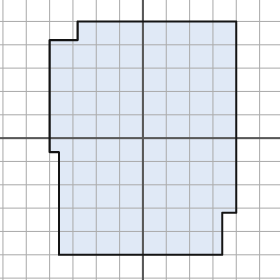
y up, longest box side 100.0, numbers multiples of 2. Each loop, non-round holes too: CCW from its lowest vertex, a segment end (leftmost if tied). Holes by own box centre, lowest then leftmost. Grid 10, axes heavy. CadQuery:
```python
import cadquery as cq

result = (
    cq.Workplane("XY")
    .moveTo(-36.0, -50.0)
    .lineTo(34.0, -50.0)
    .lineTo(34.0, -32.0)
    .lineTo(40.0, -32.0)
    .lineTo(40.0, 50.0)
    .lineTo(-28.0, 50.0)
    .lineTo(-28.0, 42.0)
    .lineTo(-40.0, 42.0)
    .lineTo(-40.0, -6.0)
    .lineTo(-36.0, -6.0)
    .close()
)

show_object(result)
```